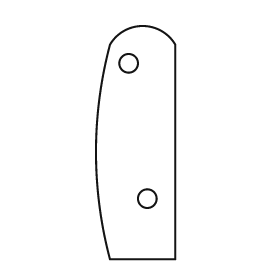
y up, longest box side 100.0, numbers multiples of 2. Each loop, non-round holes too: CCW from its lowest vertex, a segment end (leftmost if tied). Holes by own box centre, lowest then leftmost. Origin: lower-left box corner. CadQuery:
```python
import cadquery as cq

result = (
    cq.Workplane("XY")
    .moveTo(6.0, 0.0)
    .lineTo(34.0, 0.0)
    .lineTo(34.0, 92.0)
    .threePointArc((20.0, 100.0), (6.0, 92.0))
    .threePointArc((0.0, 46.0), (6.0, 0.0))
    .close()
    .moveTo(22.0, 26.0)
    .circle(4.0)
    .moveTo(14.0, 84.0)
    .circle(4.0)
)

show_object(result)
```